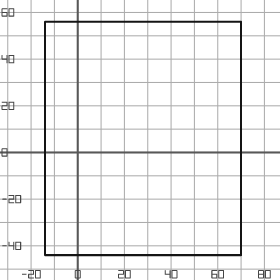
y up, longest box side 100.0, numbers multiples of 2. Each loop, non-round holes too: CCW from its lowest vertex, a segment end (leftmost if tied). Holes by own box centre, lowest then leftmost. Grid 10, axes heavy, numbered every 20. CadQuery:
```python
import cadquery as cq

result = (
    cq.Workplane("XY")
    .moveTo(-14.0, -44.0)
    .lineTo(70.0, -44.0)
    .lineTo(70.0, 56.0)
    .lineTo(-14.0, 56.0)
    .close()
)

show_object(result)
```